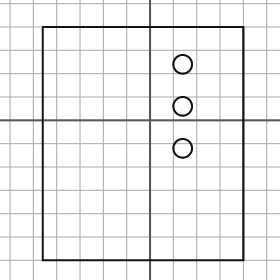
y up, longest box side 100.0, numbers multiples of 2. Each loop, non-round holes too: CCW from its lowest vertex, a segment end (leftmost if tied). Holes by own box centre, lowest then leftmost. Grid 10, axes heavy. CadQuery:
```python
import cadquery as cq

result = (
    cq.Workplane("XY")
    .moveTo(-46.0, -60.0)
    .lineTo(40.0, -60.0)
    .lineTo(40.0, 40.0)
    .lineTo(-46.0, 40.0)
    .close()
    .moveTo(14.0, -12.0)
    .circle(4.0)
    .moveTo(14.0, 6.0)
    .circle(4.0)
    .moveTo(14.0, 24.0)
    .circle(4.0)
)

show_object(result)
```